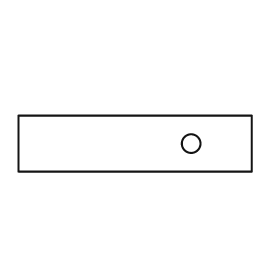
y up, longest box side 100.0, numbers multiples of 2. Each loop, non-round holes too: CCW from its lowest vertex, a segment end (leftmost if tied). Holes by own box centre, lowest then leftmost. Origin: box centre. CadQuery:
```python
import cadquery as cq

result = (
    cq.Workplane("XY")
    .moveTo(-50.0, -12.0)
    .lineTo(50.0, -12.0)
    .lineTo(50.0, 12.0)
    .lineTo(-50.0, 12.0)
    .close()
    .moveTo(24.0, 0.0)
    .circle(4.0)
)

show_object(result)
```